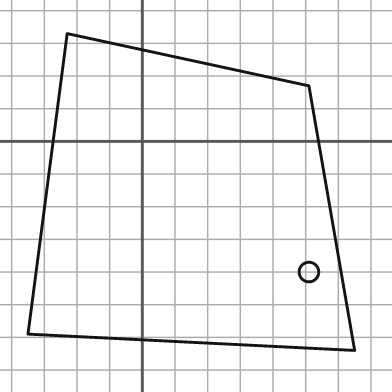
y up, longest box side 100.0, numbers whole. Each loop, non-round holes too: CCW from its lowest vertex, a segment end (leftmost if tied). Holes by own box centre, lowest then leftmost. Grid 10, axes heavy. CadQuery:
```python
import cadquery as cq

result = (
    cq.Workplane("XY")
    .moveTo(65.0, -64.0)
    .lineTo(51.0, 17.0)
    .lineTo(-23.0, 33.0)
    .lineTo(-35.0, -59.0)
    .close()
    .moveTo(51.0, -40.0)
    .circle(3.0)
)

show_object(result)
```